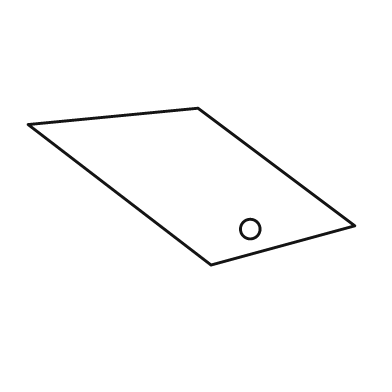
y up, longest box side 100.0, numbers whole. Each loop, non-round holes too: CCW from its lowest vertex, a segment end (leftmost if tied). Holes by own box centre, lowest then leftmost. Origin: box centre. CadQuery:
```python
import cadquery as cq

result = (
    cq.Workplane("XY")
    .moveTo(6.0, -24.0)
    .lineTo(50.0, -12.0)
    .lineTo(2.0, 24.0)
    .lineTo(-50.0, 19.0)
    .close()
    .moveTo(18.0, -13.0)
    .circle(3.0)
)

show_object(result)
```